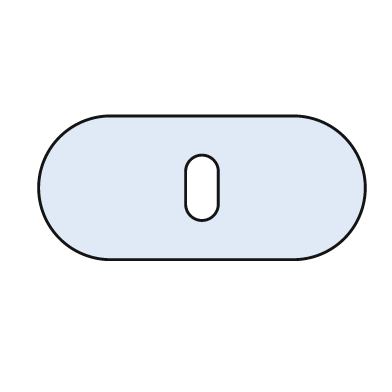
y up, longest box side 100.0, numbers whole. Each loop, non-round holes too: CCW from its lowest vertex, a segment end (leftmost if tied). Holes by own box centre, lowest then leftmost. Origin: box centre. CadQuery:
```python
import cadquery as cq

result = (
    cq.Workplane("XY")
    .moveTo(-28.0, -22.0)
    .lineTo(28.0, -22.0)
    .threePointArc((50.0, 0.0), (28.0, 22.0))
    .lineTo(-28.0, 22.0)
    .threePointArc((-50.0, 0.0), (-28.0, -22.0))
    .close()
    .moveTo(-5.0, -5.0)
    .threePointArc((0.0, -10.0), (5.0, -5.0))
    .lineTo(5.0, 5.0)
    .threePointArc((0.0, 10.0), (-5.0, 5.0))
    .close()
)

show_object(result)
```